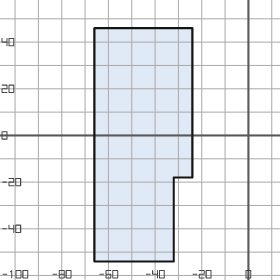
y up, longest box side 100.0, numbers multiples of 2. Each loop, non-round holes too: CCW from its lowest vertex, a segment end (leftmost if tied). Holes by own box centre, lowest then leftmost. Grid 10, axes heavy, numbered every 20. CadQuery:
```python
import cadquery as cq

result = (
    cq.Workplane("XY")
    .moveTo(-66.0, -54.0)
    .lineTo(-32.0, -54.0)
    .lineTo(-32.0, -18.0)
    .lineTo(-24.0, -18.0)
    .lineTo(-24.0, 46.0)
    .lineTo(-66.0, 46.0)
    .close()
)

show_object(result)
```